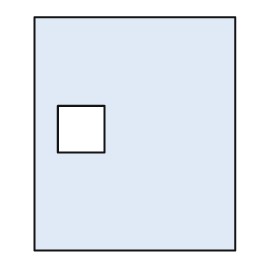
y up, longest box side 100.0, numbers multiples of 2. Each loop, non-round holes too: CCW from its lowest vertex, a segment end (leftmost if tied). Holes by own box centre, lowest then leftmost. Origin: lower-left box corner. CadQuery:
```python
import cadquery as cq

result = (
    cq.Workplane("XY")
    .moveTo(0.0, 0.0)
    .lineTo(86.0, 0.0)
    .lineTo(86.0, 100.0)
    .lineTo(0.0, 100.0)
    .close()
    .moveTo(10.0, 42.0)
    .lineTo(30.0, 42.0)
    .lineTo(30.0, 62.0)
    .lineTo(10.0, 62.0)
    .close()
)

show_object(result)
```